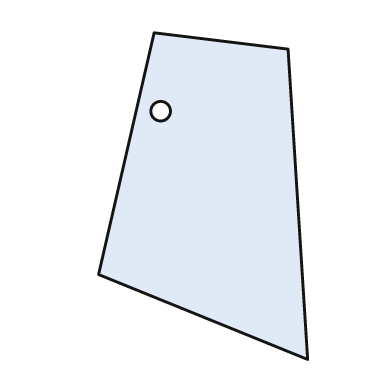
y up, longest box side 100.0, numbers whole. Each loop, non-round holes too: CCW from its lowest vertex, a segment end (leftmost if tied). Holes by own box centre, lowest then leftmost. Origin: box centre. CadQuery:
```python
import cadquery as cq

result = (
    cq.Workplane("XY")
    .moveTo(32.0, -50.0)
    .lineTo(26.0, 45.0)
    .lineTo(-15.0, 50.0)
    .lineTo(-32.0, -24.0)
    .close()
    .moveTo(-13.0, 26.0)
    .circle(3.0)
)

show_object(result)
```